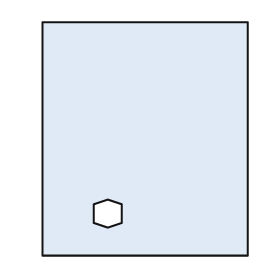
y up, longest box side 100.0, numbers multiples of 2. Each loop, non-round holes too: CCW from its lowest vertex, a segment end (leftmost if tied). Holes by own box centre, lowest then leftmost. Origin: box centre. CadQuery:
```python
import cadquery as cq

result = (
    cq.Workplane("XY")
    .moveTo(-44.0, -50.0)
    .lineTo(44.0, -50.0)
    .lineTo(44.0, 50.0)
    .lineTo(-44.0, 50.0)
    .close()
    .moveTo(-16.0, -38.0)
    .lineTo(-10.0, -36.0)
    .lineTo(-10.0, -28.0)
    .lineTo(-16.0, -26.0)
    .lineTo(-22.0, -28.0)
    .lineTo(-22.0, -36.0)
    .close()
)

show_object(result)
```